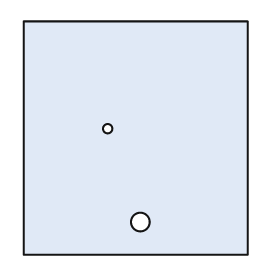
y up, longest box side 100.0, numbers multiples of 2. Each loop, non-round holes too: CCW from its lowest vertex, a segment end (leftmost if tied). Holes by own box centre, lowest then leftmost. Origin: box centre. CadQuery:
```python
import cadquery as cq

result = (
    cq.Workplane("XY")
    .moveTo(-48.0, -50.0)
    .lineTo(48.0, -50.0)
    .lineTo(48.0, 50.0)
    .lineTo(-48.0, 50.0)
    .close()
    .moveTo(2.0, -36.0)
    .circle(4.0)
    .moveTo(-12.0, 4.0)
    .circle(2.0)
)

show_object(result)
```